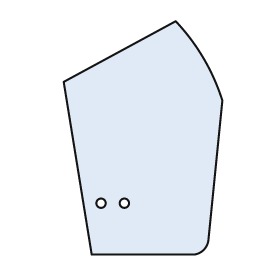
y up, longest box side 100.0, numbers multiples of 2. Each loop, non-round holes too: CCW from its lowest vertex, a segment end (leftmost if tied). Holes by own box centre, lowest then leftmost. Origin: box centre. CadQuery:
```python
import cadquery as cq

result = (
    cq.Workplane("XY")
    .moveTo(-22.0, -50.0)
    .lineTo(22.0, -50.0)
    .threePointArc((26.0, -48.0), (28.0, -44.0))
    .lineTo(34.0, 16.0)
    .threePointArc((26.0, 34.0), (14.0, 50.0))
    .lineTo(-34.0, 24.0)
    .close()
    .moveTo(-18.0, -28.0)
    .circle(2.0)
    .moveTo(-8.0, -28.0)
    .circle(2.0)
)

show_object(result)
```